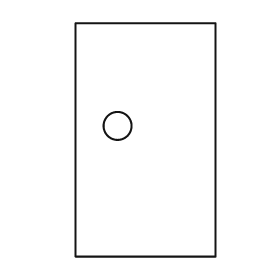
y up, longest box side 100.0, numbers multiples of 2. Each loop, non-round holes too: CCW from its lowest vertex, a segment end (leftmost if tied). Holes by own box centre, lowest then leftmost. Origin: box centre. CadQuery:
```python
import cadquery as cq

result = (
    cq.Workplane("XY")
    .moveTo(-30.0, -50.0)
    .lineTo(30.0, -50.0)
    .lineTo(30.0, 50.0)
    .lineTo(-30.0, 50.0)
    .close()
    .moveTo(-12.0, 6.0)
    .circle(6.0)
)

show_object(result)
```